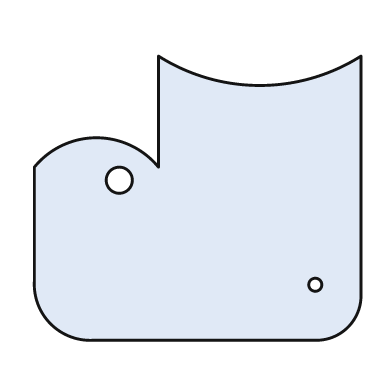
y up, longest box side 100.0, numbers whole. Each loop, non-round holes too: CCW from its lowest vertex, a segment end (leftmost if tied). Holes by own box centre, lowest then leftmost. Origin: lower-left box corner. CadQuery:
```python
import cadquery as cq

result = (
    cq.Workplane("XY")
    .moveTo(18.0, 0.0)
    .lineTo(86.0, 0.0)
    .threePointArc((96.0, 4.0), (100.0, 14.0))
    .lineTo(100.0, 87.0)
    .threePointArc((69.0, 78.0), (38.0, 87.0))
    .lineTo(38.0, 53.0)
    .threePointArc((19.0, 62.0), (0.0, 53.0))
    .lineTo(0.0, 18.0)
    .threePointArc((5.0, 5.0), (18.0, 0.0))
    .close()
    .moveTo(86.0, 17.0)
    .circle(2.0)
    .moveTo(26.0, 49.0)
    .circle(4.0)
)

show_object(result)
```